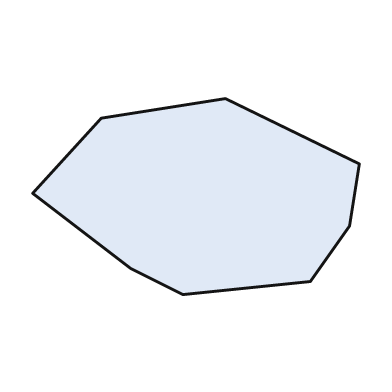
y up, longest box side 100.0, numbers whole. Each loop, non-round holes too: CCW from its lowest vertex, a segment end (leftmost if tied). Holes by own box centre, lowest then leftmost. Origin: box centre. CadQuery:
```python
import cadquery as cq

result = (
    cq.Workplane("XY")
    .moveTo(-4.0, -30.0)
    .lineTo(35.0, -26.0)
    .lineTo(47.0, -9.0)
    .lineTo(50.0, 10.0)
    .lineTo(9.0, 30.0)
    .lineTo(-29.0, 24.0)
    .lineTo(-50.0, 1.0)
    .lineTo(-20.0, -22.0)
    .close()
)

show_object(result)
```